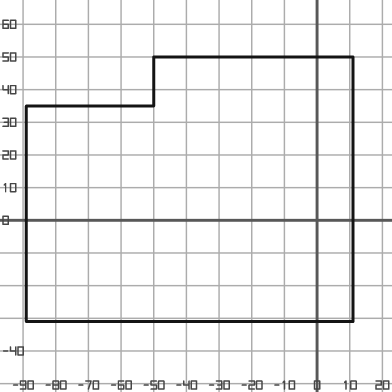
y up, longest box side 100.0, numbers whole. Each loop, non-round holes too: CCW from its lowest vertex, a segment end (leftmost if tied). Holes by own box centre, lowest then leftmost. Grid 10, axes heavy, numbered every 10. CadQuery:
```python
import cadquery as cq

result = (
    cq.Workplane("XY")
    .moveTo(-89.0, -31.0)
    .lineTo(11.0, -31.0)
    .lineTo(11.0, 50.0)
    .lineTo(-50.0, 50.0)
    .lineTo(-50.0, 35.0)
    .lineTo(-89.0, 35.0)
    .close()
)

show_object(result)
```